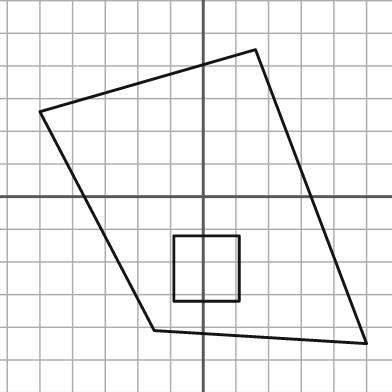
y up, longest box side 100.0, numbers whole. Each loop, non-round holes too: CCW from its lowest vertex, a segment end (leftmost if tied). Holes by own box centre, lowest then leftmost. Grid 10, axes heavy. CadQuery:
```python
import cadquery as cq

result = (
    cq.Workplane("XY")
    .moveTo(50.0, -45.0)
    .lineTo(16.0, 45.0)
    .lineTo(-50.0, 26.0)
    .lineTo(-15.0, -41.0)
    .close()
    .moveTo(-9.0, -32.0)
    .lineTo(11.0, -32.0)
    .lineTo(11.0, -12.0)
    .lineTo(-9.0, -12.0)
    .close()
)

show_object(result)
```